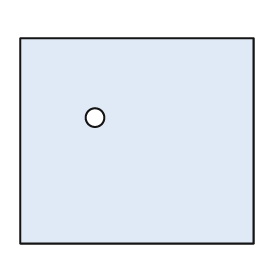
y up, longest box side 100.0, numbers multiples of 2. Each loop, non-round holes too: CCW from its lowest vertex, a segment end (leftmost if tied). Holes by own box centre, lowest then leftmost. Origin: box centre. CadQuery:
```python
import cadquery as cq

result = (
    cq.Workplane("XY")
    .moveTo(-50.0, -44.0)
    .lineTo(50.0, -44.0)
    .lineTo(50.0, 44.0)
    .lineTo(-50.0, 44.0)
    .close()
    .moveTo(-18.0, 10.0)
    .circle(4.0)
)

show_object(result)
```